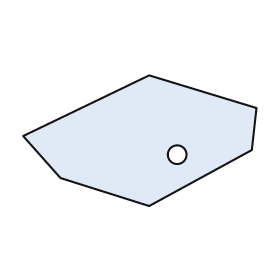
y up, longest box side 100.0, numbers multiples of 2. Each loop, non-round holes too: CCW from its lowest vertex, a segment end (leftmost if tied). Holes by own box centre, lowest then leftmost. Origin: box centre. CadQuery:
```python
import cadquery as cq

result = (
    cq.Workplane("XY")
    .moveTo(4.0, -28.0)
    .lineTo(48.0, -4.0)
    .lineTo(50.0, 14.0)
    .lineTo(4.0, 28.0)
    .lineTo(-50.0, 2.0)
    .lineTo(-34.0, -16.0)
    .close()
    .moveTo(16.0, -6.0)
    .circle(4.0)
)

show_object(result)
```